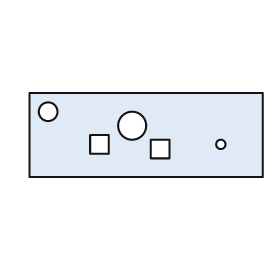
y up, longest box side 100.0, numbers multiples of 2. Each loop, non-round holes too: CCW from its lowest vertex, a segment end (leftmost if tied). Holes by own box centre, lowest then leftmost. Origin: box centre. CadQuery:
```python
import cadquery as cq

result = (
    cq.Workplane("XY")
    .moveTo(-50.0, -18.0)
    .lineTo(50.0, -18.0)
    .lineTo(50.0, 18.0)
    .lineTo(-50.0, 18.0)
    .close()
    .moveTo(2.0, -10.0)
    .lineTo(10.0, -10.0)
    .lineTo(10.0, -2.0)
    .lineTo(2.0, -2.0)
    .close()
    .moveTo(-24.0, -8.0)
    .lineTo(-16.0, -8.0)
    .lineTo(-16.0, 0.0)
    .lineTo(-24.0, 0.0)
    .close()
    .moveTo(32.0, -4.0)
    .circle(2.0)
    .moveTo(-6.0, 4.0)
    .circle(6.0)
    .moveTo(-42.0, 10.0)
    .circle(4.0)
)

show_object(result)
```